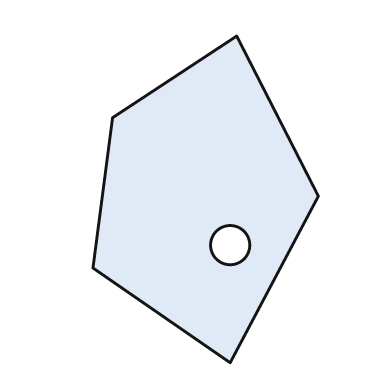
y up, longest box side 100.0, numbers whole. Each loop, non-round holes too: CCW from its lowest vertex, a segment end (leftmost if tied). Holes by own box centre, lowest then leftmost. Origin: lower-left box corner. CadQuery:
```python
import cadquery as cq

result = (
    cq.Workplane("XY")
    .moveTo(42.0, 0.0)
    .lineTo(69.0, 51.0)
    .lineTo(44.0, 100.0)
    .lineTo(6.0, 75.0)
    .lineTo(0.0, 29.0)
    .close()
    .moveTo(42.0, 36.0)
    .circle(6.0)
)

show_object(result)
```